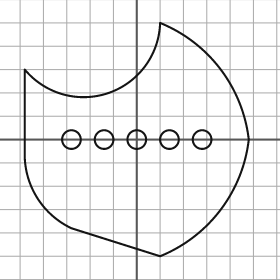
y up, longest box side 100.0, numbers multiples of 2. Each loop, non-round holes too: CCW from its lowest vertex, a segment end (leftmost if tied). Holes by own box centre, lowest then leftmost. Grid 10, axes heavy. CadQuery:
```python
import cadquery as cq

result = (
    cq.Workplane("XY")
    .moveTo(10.0, -50.0)
    .threePointArc((36.0, -30.0), (48.0, 0.0))
    .threePointArc((36.0, 30.0), (10.0, 50.0))
    .threePointArc((-12.0, 20.0), (-48.0, 30.0))
    .lineTo(-48.0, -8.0)
    .threePointArc((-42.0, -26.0), (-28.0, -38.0))
    .close()
    .moveTo(-28.0, 0.0)
    .circle(4.0)
    .moveTo(-14.0, 0.0)
    .circle(4.0)
    .moveTo(0.0, 0.0)
    .circle(4.0)
    .moveTo(14.0, 0.0)
    .circle(4.0)
    .moveTo(28.0, 0.0)
    .circle(4.0)
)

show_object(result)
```